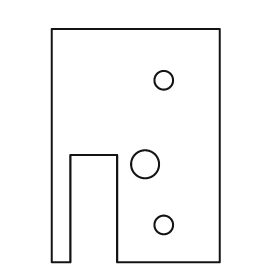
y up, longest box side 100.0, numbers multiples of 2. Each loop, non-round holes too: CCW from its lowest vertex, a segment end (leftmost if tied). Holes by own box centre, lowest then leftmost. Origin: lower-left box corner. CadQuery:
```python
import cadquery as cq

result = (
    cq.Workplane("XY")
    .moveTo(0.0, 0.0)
    .lineTo(8.0, 0.0)
    .lineTo(8.0, 46.0)
    .lineTo(28.0, 46.0)
    .lineTo(28.0, 0.0)
    .lineTo(72.0, 0.0)
    .lineTo(72.0, 100.0)
    .lineTo(0.0, 100.0)
    .close()
    .moveTo(48.0, 16.0)
    .circle(4.0)
    .moveTo(40.0, 42.0)
    .circle(6.0)
    .moveTo(48.0, 78.0)
    .circle(4.0)
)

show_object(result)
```